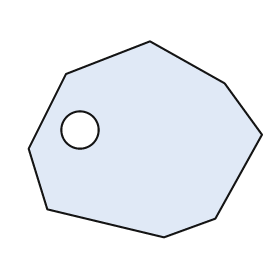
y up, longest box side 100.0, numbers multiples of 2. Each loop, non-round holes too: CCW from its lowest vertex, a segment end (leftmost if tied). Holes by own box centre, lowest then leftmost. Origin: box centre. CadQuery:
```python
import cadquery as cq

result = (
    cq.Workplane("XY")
    .moveTo(8.0, -42.0)
    .lineTo(30.0, -34.0)
    .lineTo(50.0, 2.0)
    .lineTo(34.0, 24.0)
    .lineTo(2.0, 42.0)
    .lineTo(-34.0, 28.0)
    .lineTo(-50.0, -4.0)
    .lineTo(-42.0, -30.0)
    .close()
    .moveTo(-28.0, 4.0)
    .circle(8.0)
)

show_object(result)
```